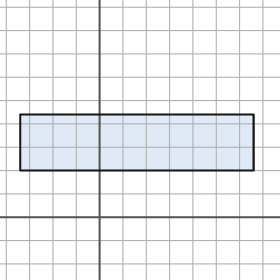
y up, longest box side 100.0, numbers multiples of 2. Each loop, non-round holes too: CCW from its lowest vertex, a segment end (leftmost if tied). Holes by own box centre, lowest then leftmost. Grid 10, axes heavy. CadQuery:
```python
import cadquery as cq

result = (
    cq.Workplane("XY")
    .moveTo(-34.0, 20.0)
    .lineTo(66.0, 20.0)
    .lineTo(66.0, 44.0)
    .lineTo(-34.0, 44.0)
    .close()
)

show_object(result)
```